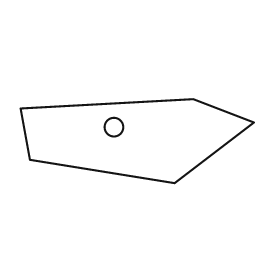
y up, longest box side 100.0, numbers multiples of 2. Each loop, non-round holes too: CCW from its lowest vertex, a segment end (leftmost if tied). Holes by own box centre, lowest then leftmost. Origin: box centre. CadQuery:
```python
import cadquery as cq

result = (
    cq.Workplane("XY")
    .moveTo(16.0, -18.0)
    .lineTo(50.0, 8.0)
    .lineTo(24.0, 18.0)
    .lineTo(-50.0, 14.0)
    .lineTo(-46.0, -8.0)
    .close()
    .moveTo(-10.0, 6.0)
    .circle(4.0)
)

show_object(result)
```